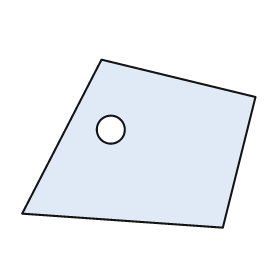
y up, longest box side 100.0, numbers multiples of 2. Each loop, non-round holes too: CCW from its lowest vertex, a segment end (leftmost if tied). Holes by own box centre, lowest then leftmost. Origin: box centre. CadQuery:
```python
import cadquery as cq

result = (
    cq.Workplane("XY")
    .moveTo(36.0, -36.0)
    .lineTo(50.0, 20.0)
    .lineTo(-16.0, 36.0)
    .lineTo(-50.0, -30.0)
    .close()
    .moveTo(-12.0, 6.0)
    .circle(6.0)
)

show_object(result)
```